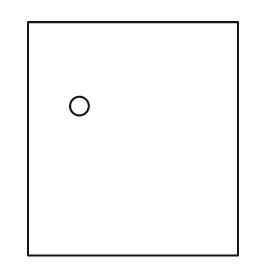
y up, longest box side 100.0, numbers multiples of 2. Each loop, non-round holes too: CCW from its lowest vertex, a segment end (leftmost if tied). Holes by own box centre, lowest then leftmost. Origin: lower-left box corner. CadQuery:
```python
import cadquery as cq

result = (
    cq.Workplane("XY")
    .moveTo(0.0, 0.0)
    .lineTo(90.0, 0.0)
    .lineTo(90.0, 100.0)
    .lineTo(0.0, 100.0)
    .close()
    .moveTo(22.0, 64.0)
    .circle(4.0)
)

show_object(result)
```